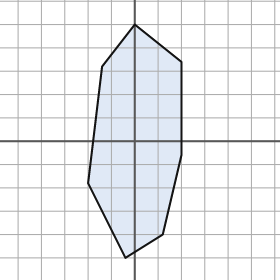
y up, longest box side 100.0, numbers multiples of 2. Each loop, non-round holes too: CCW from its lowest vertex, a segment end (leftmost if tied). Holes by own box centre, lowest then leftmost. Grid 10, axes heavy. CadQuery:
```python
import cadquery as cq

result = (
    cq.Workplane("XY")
    .moveTo(-4.0, -50.0)
    .lineTo(12.0, -40.0)
    .lineTo(20.0, -6.0)
    .lineTo(20.0, 34.0)
    .lineTo(0.0, 50.0)
    .lineTo(-14.0, 32.0)
    .lineTo(-20.0, -18.0)
    .close()
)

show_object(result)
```